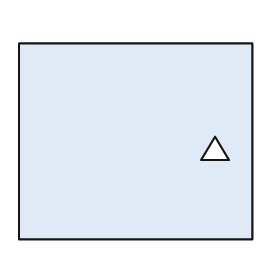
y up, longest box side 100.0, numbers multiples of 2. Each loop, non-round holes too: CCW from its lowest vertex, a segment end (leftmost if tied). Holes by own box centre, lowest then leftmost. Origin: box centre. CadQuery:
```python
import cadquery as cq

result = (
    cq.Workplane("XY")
    .moveTo(-50.0, -42.0)
    .lineTo(50.0, -42.0)
    .lineTo(50.0, 42.0)
    .lineTo(-50.0, 42.0)
    .close()
    .moveTo(28.0, -8.0)
    .lineTo(40.0, -8.0)
    .lineTo(34.0, 2.0)
    .close()
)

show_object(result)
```